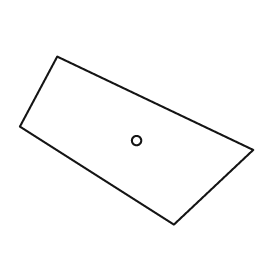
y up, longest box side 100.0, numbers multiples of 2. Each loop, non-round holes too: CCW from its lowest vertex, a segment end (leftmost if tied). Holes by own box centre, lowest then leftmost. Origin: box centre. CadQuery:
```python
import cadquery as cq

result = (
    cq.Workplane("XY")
    .moveTo(16.0, -36.0)
    .lineTo(50.0, -4.0)
    .lineTo(-34.0, 36.0)
    .lineTo(-50.0, 6.0)
    .close()
    .moveTo(0.0, 0.0)
    .circle(2.0)
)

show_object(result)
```